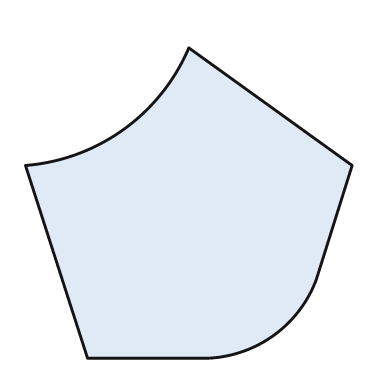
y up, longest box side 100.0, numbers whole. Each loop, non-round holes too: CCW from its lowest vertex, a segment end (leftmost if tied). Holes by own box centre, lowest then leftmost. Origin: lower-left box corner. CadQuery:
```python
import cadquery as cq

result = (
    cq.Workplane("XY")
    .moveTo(19.0, 0.0)
    .lineTo(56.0, 0.0)
    .threePointArc((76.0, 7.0), (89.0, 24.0))
    .lineTo(100.0, 59.0)
    .lineTo(50.0, 95.0)
    .threePointArc((30.0, 70.0), (0.0, 59.0))
    .close()
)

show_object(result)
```